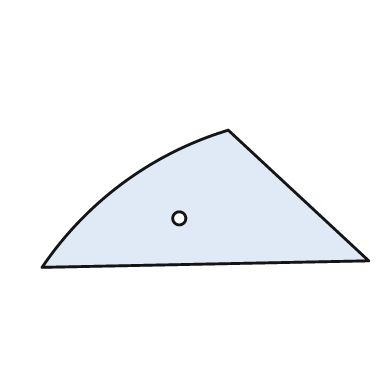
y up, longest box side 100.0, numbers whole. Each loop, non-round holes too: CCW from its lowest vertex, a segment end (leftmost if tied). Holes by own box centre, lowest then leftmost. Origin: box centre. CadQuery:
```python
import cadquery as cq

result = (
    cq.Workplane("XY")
    .moveTo(-50.0, -21.0)
    .lineTo(50.0, -19.0)
    .lineTo(7.0, 21.0)
    .threePointArc((-25.0, 5.0), (-50.0, -21.0))
    .close()
    .moveTo(-8.0, -6.0)
    .circle(2.0)
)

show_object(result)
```